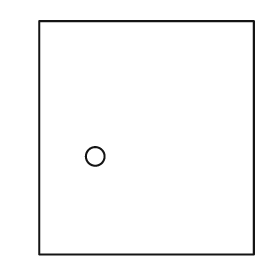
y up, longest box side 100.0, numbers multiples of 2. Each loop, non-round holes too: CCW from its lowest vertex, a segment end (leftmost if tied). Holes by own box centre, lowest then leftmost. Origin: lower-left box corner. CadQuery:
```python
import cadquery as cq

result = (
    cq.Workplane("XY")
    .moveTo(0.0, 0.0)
    .lineTo(92.0, 0.0)
    .lineTo(92.0, 100.0)
    .lineTo(0.0, 100.0)
    .close()
    .moveTo(24.0, 42.0)
    .circle(4.0)
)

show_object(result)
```